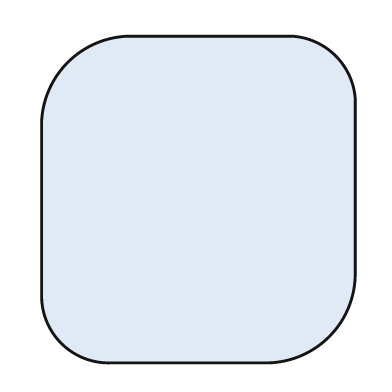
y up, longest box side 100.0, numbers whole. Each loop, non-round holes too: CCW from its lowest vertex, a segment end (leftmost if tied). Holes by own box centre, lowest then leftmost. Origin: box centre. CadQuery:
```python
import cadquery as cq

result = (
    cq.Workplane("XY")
    .moveTo(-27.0, -50.0)
    .lineTo(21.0, -50.0)
    .threePointArc((40.0, -42.0), (48.0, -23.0))
    .lineTo(48.0, 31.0)
    .threePointArc((42.0, 44.0), (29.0, 50.0))
    .lineTo(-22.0, 50.0)
    .threePointArc((-40.0, 42.0), (-48.0, 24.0))
    .lineTo(-48.0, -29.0)
    .threePointArc((-42.0, -44.0), (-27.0, -50.0))
    .close()
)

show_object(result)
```